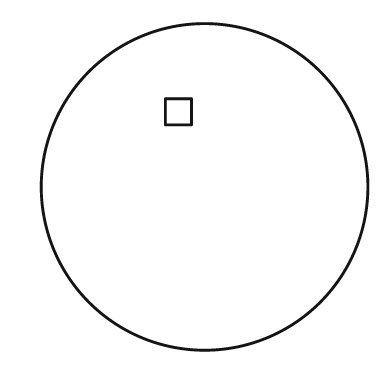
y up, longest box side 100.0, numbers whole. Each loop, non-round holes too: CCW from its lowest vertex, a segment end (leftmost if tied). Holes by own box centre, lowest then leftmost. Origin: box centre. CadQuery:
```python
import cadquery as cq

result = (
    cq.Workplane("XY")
    .moveTo(0.0, 0.0)
    .circle(50.0)
    .moveTo(-12.0, 19.0)
    .lineTo(-4.0, 19.0)
    .lineTo(-4.0, 27.0)
    .lineTo(-12.0, 27.0)
    .close()
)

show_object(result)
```